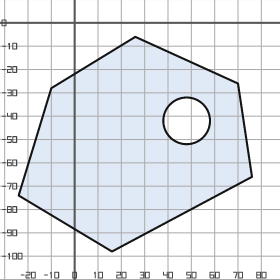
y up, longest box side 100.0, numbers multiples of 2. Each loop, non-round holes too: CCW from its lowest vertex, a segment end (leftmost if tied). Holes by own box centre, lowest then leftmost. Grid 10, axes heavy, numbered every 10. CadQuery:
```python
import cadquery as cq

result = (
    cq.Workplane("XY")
    .moveTo(16.0, -98.0)
    .lineTo(76.0, -66.0)
    .lineTo(70.0, -26.0)
    .lineTo(26.0, -6.0)
    .lineTo(-10.0, -28.0)
    .lineTo(-24.0, -74.0)
    .close()
    .moveTo(48.0, -42.0)
    .circle(10.0)
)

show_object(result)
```